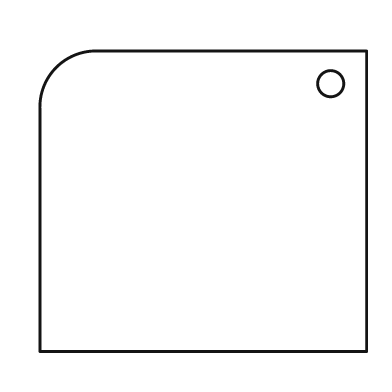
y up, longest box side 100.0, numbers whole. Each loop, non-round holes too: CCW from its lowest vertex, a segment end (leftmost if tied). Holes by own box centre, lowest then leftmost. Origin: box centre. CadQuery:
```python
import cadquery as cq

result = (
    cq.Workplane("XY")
    .moveTo(-50.0, -46.0)
    .lineTo(50.0, -46.0)
    .lineTo(50.0, 46.0)
    .lineTo(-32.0, 46.0)
    .threePointArc((-45.0, 41.0), (-50.0, 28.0))
    .close()
    .moveTo(39.0, 36.0)
    .circle(4.0)
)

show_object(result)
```